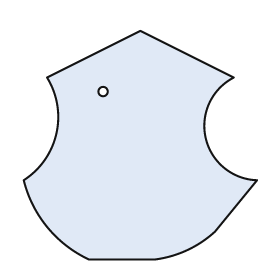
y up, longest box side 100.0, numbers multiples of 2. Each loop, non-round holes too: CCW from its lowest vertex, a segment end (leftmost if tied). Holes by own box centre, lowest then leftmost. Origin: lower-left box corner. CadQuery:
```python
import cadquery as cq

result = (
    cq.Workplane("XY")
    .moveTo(28.0, 0.0)
    .lineTo(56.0, 0.0)
    .threePointArc((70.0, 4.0), (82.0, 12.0))
    .lineTo(100.0, 34.0)
    .threePointArc((78.0, 52.0), (90.0, 78.0))
    .lineTo(50.0, 98.0)
    .lineTo(10.0, 78.0)
    .threePointArc((14.0, 54.0), (0.0, 34.0))
    .threePointArc((10.0, 14.0), (28.0, 0.0))
    .close()
    .moveTo(34.0, 72.0)
    .circle(2.0)
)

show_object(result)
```